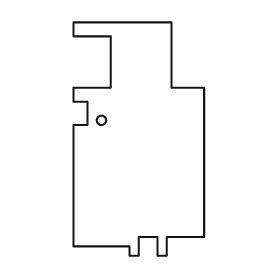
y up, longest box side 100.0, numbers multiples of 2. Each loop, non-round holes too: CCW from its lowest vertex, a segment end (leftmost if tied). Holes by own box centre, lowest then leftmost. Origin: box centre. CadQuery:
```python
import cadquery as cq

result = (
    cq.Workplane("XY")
    .moveTo(-4.0, -50.0)
    .lineTo(0.0, -50.0)
    .lineTo(0.0, -42.0)
    .lineTo(8.0, -42.0)
    .lineTo(8.0, -50.0)
    .lineTo(12.0, -50.0)
    .lineTo(12.0, -42.0)
    .lineTo(28.0, -42.0)
    .lineTo(28.0, 22.0)
    .lineTo(14.0, 22.0)
    .lineTo(14.0, 50.0)
    .lineTo(-28.0, 50.0)
    .lineTo(-28.0, 44.0)
    .lineTo(-12.0, 44.0)
    .lineTo(-12.0, 22.0)
    .lineTo(-28.0, 22.0)
    .lineTo(-28.0, 16.0)
    .lineTo(-22.0, 16.0)
    .lineTo(-22.0, 6.0)
    .lineTo(-28.0, 6.0)
    .lineTo(-28.0, -46.0)
    .lineTo(-4.0, -46.0)
    .close()
    .moveTo(-16.0, 8.0)
    .circle(2.0)
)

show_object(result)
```